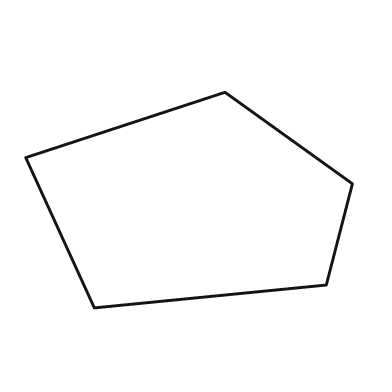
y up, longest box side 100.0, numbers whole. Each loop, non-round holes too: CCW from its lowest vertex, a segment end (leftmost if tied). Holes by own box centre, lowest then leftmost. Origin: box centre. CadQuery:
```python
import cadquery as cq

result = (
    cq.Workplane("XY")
    .moveTo(-29.0, -33.0)
    .lineTo(42.0, -26.0)
    .lineTo(50.0, 5.0)
    .lineTo(11.0, 33.0)
    .lineTo(-50.0, 13.0)
    .close()
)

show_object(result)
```